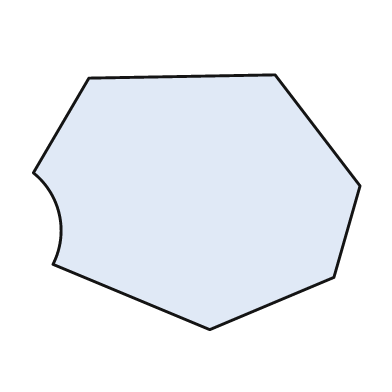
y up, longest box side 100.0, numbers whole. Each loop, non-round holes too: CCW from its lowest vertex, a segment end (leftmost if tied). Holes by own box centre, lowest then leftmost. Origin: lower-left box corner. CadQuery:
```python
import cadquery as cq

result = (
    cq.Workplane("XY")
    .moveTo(54.0, 0.0)
    .lineTo(92.0, 16.0)
    .lineTo(100.0, 44.0)
    .lineTo(74.0, 78.0)
    .lineTo(17.0, 77.0)
    .lineTo(0.0, 48.0)
    .threePointArc((8.0, 35.0), (6.0, 20.0))
    .close()
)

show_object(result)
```